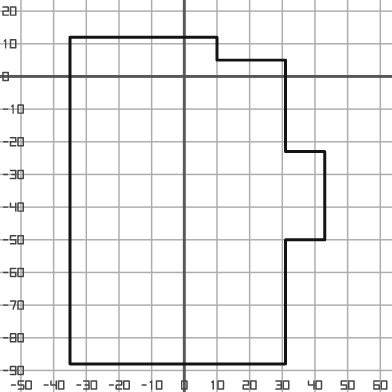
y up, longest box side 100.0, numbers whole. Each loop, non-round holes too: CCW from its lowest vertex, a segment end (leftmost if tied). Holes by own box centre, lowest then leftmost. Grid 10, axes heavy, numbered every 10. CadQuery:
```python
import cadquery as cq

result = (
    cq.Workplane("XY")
    .moveTo(-35.0, -88.0)
    .lineTo(31.0, -88.0)
    .lineTo(31.0, -50.0)
    .lineTo(43.0, -50.0)
    .lineTo(43.0, -23.0)
    .lineTo(31.0, -23.0)
    .lineTo(31.0, 5.0)
    .lineTo(10.0, 5.0)
    .lineTo(10.0, 12.0)
    .lineTo(-35.0, 12.0)
    .close()
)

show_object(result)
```